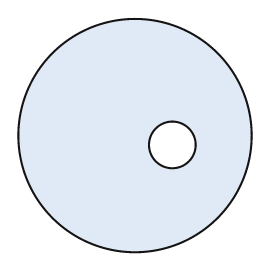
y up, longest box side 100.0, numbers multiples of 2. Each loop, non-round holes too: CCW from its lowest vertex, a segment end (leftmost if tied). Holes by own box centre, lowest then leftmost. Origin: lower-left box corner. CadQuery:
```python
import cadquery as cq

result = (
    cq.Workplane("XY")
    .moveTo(50.0, 50.0)
    .circle(50.0)
    .moveTo(66.0, 46.0)
    .circle(10.0)
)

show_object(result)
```